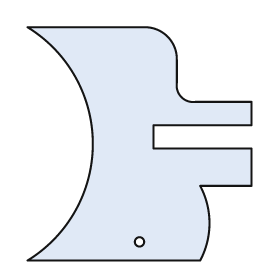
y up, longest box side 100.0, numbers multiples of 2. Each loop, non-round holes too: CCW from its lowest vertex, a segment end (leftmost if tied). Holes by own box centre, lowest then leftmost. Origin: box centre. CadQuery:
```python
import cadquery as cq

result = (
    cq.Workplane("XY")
    .moveTo(-48.0, -50.0)
    .lineTo(26.0, -50.0)
    .threePointArc((30.0, -34.0), (26.0, -18.0))
    .lineTo(48.0, -18.0)
    .lineTo(48.0, -2.0)
    .lineTo(6.0, -2.0)
    .lineTo(6.0, 8.0)
    .lineTo(48.0, 8.0)
    .lineTo(48.0, 18.0)
    .lineTo(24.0, 18.0)
    .threePointArc((18.0, 20.0), (16.0, 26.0))
    .lineTo(16.0, 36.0)
    .threePointArc((12.0, 46.0), (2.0, 50.0))
    .lineTo(-48.0, 50.0)
    .threePointArc((-20.0, 0.0), (-48.0, -50.0))
    .close()
    .moveTo(0.0, -42.0)
    .circle(2.0)
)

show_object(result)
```